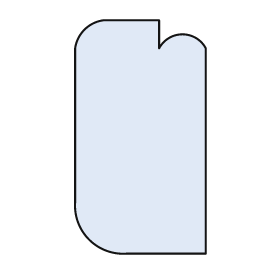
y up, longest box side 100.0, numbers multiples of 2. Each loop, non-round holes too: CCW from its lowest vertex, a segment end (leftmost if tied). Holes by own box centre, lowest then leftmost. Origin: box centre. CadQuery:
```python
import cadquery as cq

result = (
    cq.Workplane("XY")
    .moveTo(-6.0, -50.0)
    .lineTo(28.0, -50.0)
    .lineTo(28.0, 38.0)
    .threePointArc((18.0, 44.0), (8.0, 38.0))
    .lineTo(8.0, 50.0)
    .lineTo(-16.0, 50.0)
    .threePointArc((-24.0, 46.0), (-28.0, 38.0))
    .lineTo(-28.0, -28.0)
    .threePointArc((-22.0, -44.0), (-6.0, -50.0))
    .close()
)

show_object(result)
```